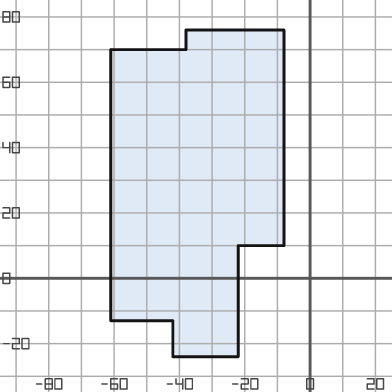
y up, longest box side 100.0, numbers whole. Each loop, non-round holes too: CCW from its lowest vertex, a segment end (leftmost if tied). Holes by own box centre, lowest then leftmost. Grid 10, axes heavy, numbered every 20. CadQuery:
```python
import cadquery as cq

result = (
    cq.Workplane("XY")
    .moveTo(-42.0, -24.0)
    .lineTo(-22.0, -24.0)
    .lineTo(-22.0, 10.0)
    .lineTo(-8.0, 10.0)
    .lineTo(-8.0, 76.0)
    .lineTo(-38.0, 76.0)
    .lineTo(-38.0, 70.0)
    .lineTo(-61.0, 70.0)
    .lineTo(-61.0, -13.0)
    .lineTo(-42.0, -13.0)
    .close()
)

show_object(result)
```